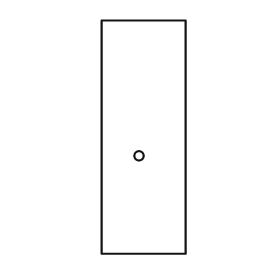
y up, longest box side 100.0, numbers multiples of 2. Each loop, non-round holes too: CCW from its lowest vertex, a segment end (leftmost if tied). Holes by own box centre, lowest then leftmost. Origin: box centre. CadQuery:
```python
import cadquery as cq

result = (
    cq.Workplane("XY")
    .moveTo(-18.0, -50.0)
    .lineTo(18.0, -50.0)
    .lineTo(18.0, 50.0)
    .lineTo(-18.0, 50.0)
    .close()
    .moveTo(-2.0, -8.0)
    .circle(2.0)
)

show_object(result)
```